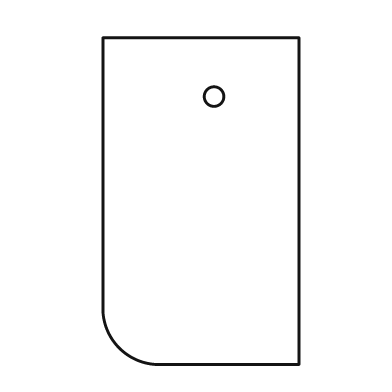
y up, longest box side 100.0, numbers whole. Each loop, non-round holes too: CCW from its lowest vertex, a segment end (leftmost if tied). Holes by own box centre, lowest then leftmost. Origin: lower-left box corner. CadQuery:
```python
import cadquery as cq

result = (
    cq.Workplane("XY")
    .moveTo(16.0, 0.0)
    .lineTo(60.0, 0.0)
    .lineTo(60.0, 100.0)
    .lineTo(0.0, 100.0)
    .lineTo(0.0, 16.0)
    .threePointArc((5.0, 5.0), (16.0, 0.0))
    .close()
    .moveTo(34.0, 82.0)
    .circle(3.0)
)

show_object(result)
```